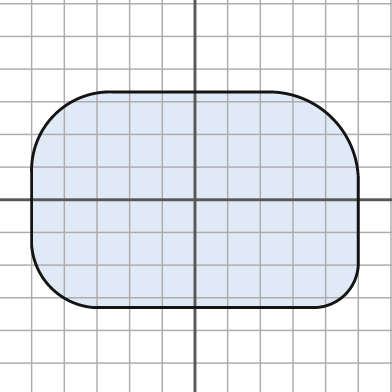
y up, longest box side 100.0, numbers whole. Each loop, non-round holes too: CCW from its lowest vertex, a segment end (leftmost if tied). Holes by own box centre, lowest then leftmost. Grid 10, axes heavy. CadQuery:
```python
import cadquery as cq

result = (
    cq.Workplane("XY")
    .moveTo(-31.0, -33.0)
    .lineTo(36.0, -33.0)
    .threePointArc((46.0, -29.0), (50.0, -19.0))
    .lineTo(50.0, 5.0)
    .threePointArc((42.0, 25.0), (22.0, 33.0))
    .lineTo(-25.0, 33.0)
    .threePointArc((-43.0, 26.0), (-50.0, 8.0))
    .lineTo(-50.0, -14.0)
    .threePointArc((-44.0, -27.0), (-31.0, -33.0))
    .close()
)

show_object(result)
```